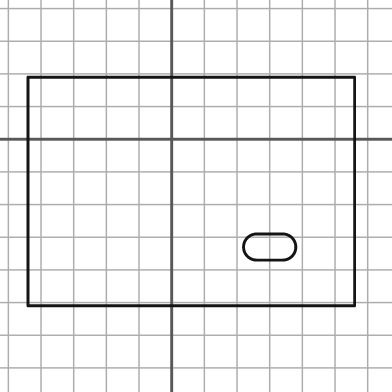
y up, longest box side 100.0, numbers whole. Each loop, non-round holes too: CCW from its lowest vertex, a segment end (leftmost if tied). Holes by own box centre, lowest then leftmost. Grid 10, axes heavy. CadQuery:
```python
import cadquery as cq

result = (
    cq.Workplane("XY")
    .moveTo(-44.0, -51.0)
    .lineTo(56.0, -51.0)
    .lineTo(56.0, 19.0)
    .lineTo(-44.0, 19.0)
    .close()
    .moveTo(26.0, -37.0)
    .lineTo(34.0, -37.0)
    .threePointArc((38.0, -33.0), (34.0, -29.0))
    .lineTo(26.0, -29.0)
    .threePointArc((22.0, -33.0), (26.0, -37.0))
    .close()
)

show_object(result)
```